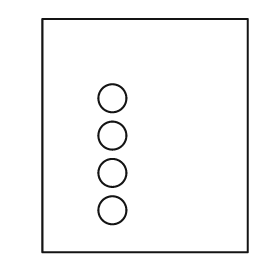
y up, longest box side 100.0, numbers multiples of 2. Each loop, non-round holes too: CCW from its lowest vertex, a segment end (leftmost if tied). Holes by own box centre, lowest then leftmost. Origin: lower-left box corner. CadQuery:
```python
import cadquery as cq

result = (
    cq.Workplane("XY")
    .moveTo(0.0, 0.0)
    .lineTo(88.0, 0.0)
    .lineTo(88.0, 100.0)
    .lineTo(0.0, 100.0)
    .close()
    .moveTo(30.0, 18.0)
    .circle(6.0)
    .moveTo(30.0, 34.0)
    .circle(6.0)
    .moveTo(30.0, 50.0)
    .circle(6.0)
    .moveTo(30.0, 66.0)
    .circle(6.0)
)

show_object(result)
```